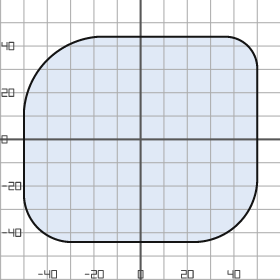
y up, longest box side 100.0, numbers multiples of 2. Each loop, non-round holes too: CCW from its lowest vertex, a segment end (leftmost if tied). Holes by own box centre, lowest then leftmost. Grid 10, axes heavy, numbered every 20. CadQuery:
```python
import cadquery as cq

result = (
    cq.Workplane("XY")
    .moveTo(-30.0, -44.0)
    .lineTo(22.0, -44.0)
    .threePointArc((42.0, -36.0), (50.0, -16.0))
    .lineTo(50.0, 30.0)
    .threePointArc((46.0, 40.0), (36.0, 44.0))
    .lineTo(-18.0, 44.0)
    .threePointArc((-40.0, 34.0), (-50.0, 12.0))
    .lineTo(-50.0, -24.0)
    .threePointArc((-44.0, -38.0), (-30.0, -44.0))
    .close()
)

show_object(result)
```